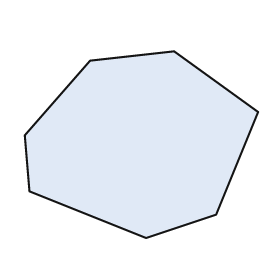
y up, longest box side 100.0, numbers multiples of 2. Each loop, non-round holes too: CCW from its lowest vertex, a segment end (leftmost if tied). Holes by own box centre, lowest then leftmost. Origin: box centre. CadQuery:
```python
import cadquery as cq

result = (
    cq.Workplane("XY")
    .moveTo(2.0, -40.0)
    .lineTo(32.0, -30.0)
    .lineTo(50.0, 14.0)
    .lineTo(14.0, 40.0)
    .lineTo(-22.0, 36.0)
    .lineTo(-50.0, 4.0)
    .lineTo(-48.0, -20.0)
    .close()
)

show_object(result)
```